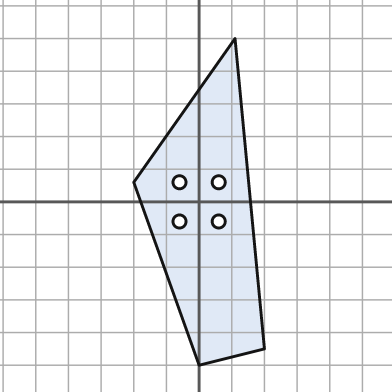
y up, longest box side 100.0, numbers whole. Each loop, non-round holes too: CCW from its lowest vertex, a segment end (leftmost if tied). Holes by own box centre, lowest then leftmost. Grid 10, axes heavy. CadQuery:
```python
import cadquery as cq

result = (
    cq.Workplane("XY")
    .moveTo(0.0, -50.0)
    .lineTo(20.0, -45.0)
    .lineTo(11.0, 50.0)
    .lineTo(-20.0, 6.0)
    .close()
    .moveTo(-6.0, -6.0)
    .circle(2.0)
    .moveTo(6.0, -6.0)
    .circle(2.0)
    .moveTo(-6.0, 6.0)
    .circle(2.0)
    .moveTo(6.0, 6.0)
    .circle(2.0)
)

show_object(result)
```